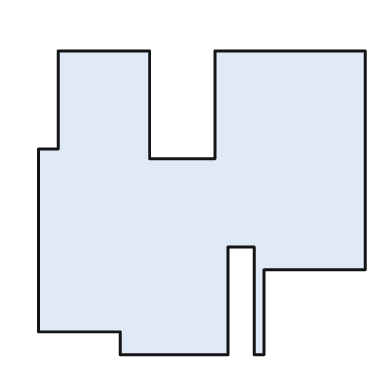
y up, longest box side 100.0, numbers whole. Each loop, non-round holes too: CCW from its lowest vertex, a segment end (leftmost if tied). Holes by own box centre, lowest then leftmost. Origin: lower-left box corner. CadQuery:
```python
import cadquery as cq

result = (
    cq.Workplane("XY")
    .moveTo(25.0, 0.0)
    .lineTo(58.0, 0.0)
    .lineTo(58.0, 33.0)
    .lineTo(66.0, 33.0)
    .lineTo(66.0, 0.0)
    .lineTo(69.0, 0.0)
    .lineTo(69.0, 26.0)
    .lineTo(100.0, 26.0)
    .lineTo(100.0, 93.0)
    .lineTo(54.0, 93.0)
    .lineTo(54.0, 60.0)
    .lineTo(34.0, 60.0)
    .lineTo(34.0, 93.0)
    .lineTo(6.0, 93.0)
    .lineTo(6.0, 63.0)
    .lineTo(0.0, 63.0)
    .lineTo(0.0, 7.0)
    .lineTo(25.0, 7.0)
    .close()
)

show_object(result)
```